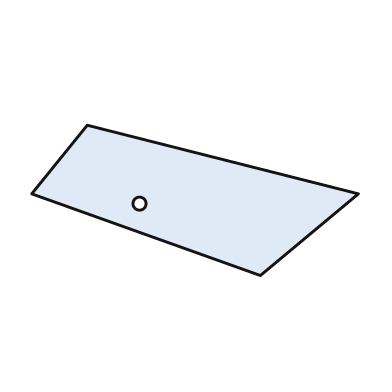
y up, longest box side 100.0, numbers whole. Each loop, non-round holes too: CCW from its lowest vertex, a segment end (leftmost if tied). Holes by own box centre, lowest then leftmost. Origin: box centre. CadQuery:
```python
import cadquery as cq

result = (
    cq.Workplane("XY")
    .moveTo(20.0, -23.0)
    .lineTo(50.0, 2.0)
    .lineTo(-33.0, 23.0)
    .lineTo(-50.0, 2.0)
    .close()
    .moveTo(-17.0, -1.0)
    .circle(2.0)
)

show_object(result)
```